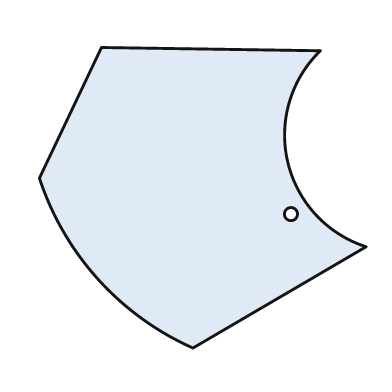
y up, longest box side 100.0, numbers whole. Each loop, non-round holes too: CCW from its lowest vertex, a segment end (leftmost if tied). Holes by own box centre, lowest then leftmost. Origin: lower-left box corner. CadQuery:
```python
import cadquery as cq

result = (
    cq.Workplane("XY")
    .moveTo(47.0, 0.0)
    .lineTo(100.0, 31.0)
    .threePointArc((76.0, 57.0), (86.0, 91.0))
    .lineTo(19.0, 92.0)
    .lineTo(0.0, 52.0)
    .threePointArc((18.0, 21.0), (47.0, 0.0))
    .close()
    .moveTo(77.0, 41.0)
    .circle(2.0)
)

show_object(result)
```